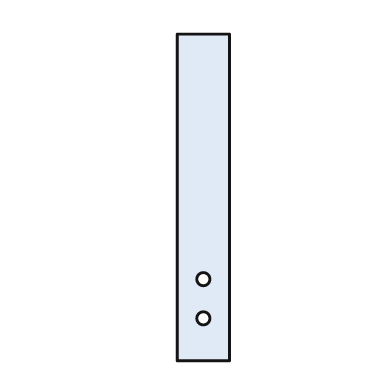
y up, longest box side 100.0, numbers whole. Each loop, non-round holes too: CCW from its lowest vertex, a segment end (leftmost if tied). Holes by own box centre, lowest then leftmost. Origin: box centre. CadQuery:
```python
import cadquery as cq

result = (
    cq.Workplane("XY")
    .moveTo(-8.0, -50.0)
    .lineTo(8.0, -50.0)
    .lineTo(8.0, 50.0)
    .lineTo(-8.0, 50.0)
    .close()
    .moveTo(0.0, -37.0)
    .circle(2.0)
    .moveTo(0.0, -25.0)
    .circle(2.0)
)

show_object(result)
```